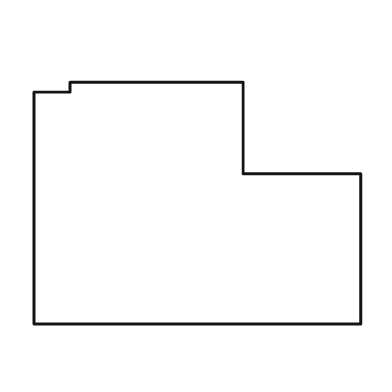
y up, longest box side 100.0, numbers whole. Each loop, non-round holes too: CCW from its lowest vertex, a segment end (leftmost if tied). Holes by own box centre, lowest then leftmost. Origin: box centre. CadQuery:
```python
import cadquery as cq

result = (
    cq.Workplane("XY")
    .moveTo(-50.0, -37.0)
    .lineTo(50.0, -37.0)
    .lineTo(50.0, 9.0)
    .lineTo(14.0, 9.0)
    .lineTo(14.0, 37.0)
    .lineTo(-39.0, 37.0)
    .lineTo(-39.0, 34.0)
    .lineTo(-50.0, 34.0)
    .close()
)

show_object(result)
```